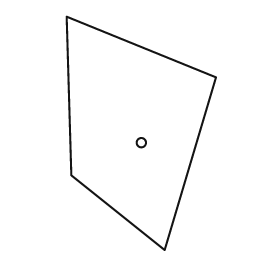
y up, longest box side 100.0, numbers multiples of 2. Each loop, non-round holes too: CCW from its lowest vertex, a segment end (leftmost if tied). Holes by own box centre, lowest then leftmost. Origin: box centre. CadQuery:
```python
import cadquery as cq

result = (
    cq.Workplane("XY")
    .moveTo(10.0, -50.0)
    .lineTo(32.0, 24.0)
    .lineTo(-32.0, 50.0)
    .lineTo(-30.0, -18.0)
    .close()
    .moveTo(0.0, -4.0)
    .circle(2.0)
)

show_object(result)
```